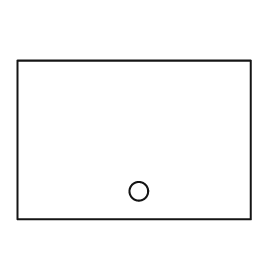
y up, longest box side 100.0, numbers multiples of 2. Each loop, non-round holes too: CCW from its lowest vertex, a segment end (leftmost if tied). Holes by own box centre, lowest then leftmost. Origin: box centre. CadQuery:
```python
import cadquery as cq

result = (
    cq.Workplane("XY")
    .moveTo(-50.0, -34.0)
    .lineTo(50.0, -34.0)
    .lineTo(50.0, 34.0)
    .lineTo(-50.0, 34.0)
    .close()
    .moveTo(2.0, -22.0)
    .circle(4.0)
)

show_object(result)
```